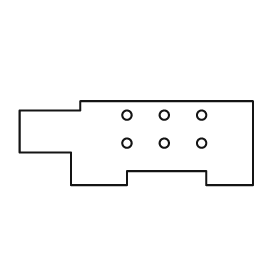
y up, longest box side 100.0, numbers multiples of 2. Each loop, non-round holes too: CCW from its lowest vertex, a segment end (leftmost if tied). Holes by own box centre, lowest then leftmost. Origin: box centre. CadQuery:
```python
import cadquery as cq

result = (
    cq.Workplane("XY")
    .moveTo(-28.0, -18.0)
    .lineTo(-4.0, -18.0)
    .lineTo(-4.0, -12.0)
    .lineTo(30.0, -12.0)
    .lineTo(30.0, -18.0)
    .lineTo(50.0, -18.0)
    .lineTo(50.0, 18.0)
    .lineTo(-24.0, 18.0)
    .lineTo(-24.0, 14.0)
    .lineTo(-50.0, 14.0)
    .lineTo(-50.0, -4.0)
    .lineTo(-28.0, -4.0)
    .close()
    .moveTo(-4.0, 0.0)
    .circle(2.0)
    .moveTo(12.0, 0.0)
    .circle(2.0)
    .moveTo(28.0, 0.0)
    .circle(2.0)
    .moveTo(-4.0, 12.0)
    .circle(2.0)
    .moveTo(12.0, 12.0)
    .circle(2.0)
    .moveTo(28.0, 12.0)
    .circle(2.0)
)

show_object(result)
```